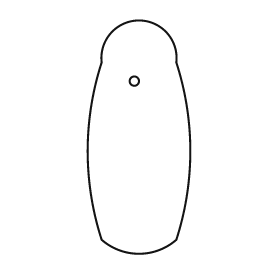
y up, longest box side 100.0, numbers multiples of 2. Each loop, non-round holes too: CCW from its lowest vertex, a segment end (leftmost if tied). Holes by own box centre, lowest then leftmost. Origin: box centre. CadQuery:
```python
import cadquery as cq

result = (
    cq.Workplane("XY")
    .moveTo(-16.0, -44.0)
    .threePointArc((0.0, -50.0), (16.0, -44.0))
    .threePointArc((22.0, -6.0), (16.0, 32.0))
    .threePointArc((0.0, 50.0), (-16.0, 32.0))
    .threePointArc((-22.0, -6.0), (-16.0, -44.0))
    .close()
    .moveTo(-2.0, 24.0)
    .circle(2.0)
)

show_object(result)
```